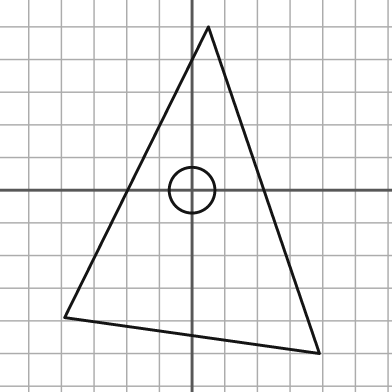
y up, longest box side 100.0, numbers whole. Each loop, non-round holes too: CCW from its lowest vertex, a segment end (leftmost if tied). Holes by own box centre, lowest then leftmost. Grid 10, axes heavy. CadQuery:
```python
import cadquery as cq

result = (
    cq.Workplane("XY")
    .moveTo(39.0, -50.0)
    .lineTo(5.0, 50.0)
    .lineTo(-39.0, -39.0)
    .close()
    .moveTo(0.0, 0.0)
    .circle(7.0)
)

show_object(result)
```